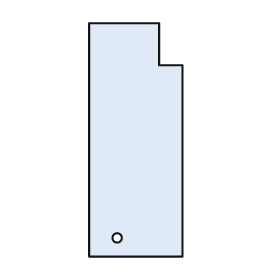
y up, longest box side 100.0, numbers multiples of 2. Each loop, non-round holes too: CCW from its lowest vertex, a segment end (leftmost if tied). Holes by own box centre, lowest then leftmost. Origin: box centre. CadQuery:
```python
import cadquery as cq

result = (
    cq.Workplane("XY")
    .moveTo(-20.0, -50.0)
    .lineTo(20.0, -50.0)
    .lineTo(20.0, 32.0)
    .lineTo(10.0, 32.0)
    .lineTo(10.0, 50.0)
    .lineTo(-20.0, 50.0)
    .close()
    .moveTo(-8.0, -42.0)
    .circle(2.0)
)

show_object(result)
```